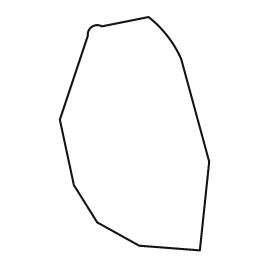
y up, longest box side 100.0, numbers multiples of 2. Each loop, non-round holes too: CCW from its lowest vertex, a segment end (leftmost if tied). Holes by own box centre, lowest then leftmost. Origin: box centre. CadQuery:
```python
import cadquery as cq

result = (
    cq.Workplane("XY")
    .moveTo(28.0, -50.0)
    .lineTo(32.0, -12.0)
    .lineTo(20.0, 32.0)
    .threePointArc((14.0, 42.0), (6.0, 50.0))
    .lineTo(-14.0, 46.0)
    .threePointArc((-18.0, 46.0), (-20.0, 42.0))
    .lineTo(-32.0, 6.0)
    .lineTo(-26.0, -22.0)
    .lineTo(-16.0, -38.0)
    .lineTo(2.0, -48.0)
    .close()
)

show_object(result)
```